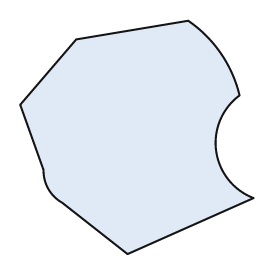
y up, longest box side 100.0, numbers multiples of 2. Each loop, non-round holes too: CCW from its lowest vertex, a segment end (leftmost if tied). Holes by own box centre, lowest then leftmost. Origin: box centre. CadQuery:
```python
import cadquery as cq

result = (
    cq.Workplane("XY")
    .moveTo(-4.0, -50.0)
    .lineTo(50.0, -26.0)
    .threePointArc((34.0, -6.0), (44.0, 18.0))
    .threePointArc((36.0, 36.0), (22.0, 50.0))
    .lineTo(-26.0, 42.0)
    .lineTo(-50.0, 14.0)
    .lineTo(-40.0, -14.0)
    .threePointArc((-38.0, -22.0), (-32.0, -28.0))
    .close()
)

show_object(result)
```